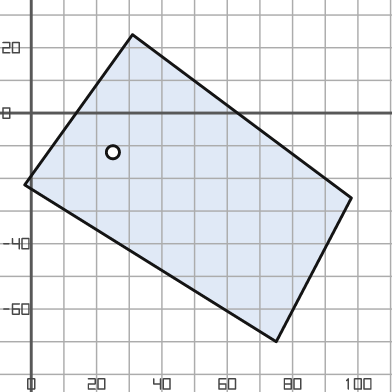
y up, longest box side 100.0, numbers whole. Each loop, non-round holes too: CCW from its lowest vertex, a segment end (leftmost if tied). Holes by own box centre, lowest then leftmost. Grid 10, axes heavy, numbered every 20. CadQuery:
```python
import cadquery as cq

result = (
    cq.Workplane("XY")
    .moveTo(75.0, -70.0)
    .lineTo(98.0, -26.0)
    .lineTo(31.0, 24.0)
    .lineTo(-2.0, -22.0)
    .close()
    .moveTo(25.0, -12.0)
    .circle(2.0)
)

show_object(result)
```